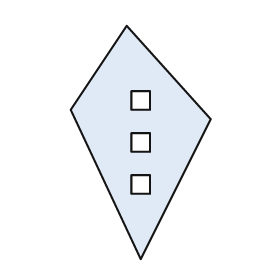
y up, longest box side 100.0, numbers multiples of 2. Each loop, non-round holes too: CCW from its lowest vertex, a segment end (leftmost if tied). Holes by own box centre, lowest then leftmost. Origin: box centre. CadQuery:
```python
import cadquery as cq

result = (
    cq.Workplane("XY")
    .moveTo(0.0, -50.0)
    .lineTo(30.0, 10.0)
    .lineTo(-6.0, 50.0)
    .lineTo(-30.0, 14.0)
    .close()
    .moveTo(-4.0, -22.0)
    .lineTo(4.0, -22.0)
    .lineTo(4.0, -14.0)
    .lineTo(-4.0, -14.0)
    .close()
    .moveTo(-4.0, -4.0)
    .lineTo(4.0, -4.0)
    .lineTo(4.0, 4.0)
    .lineTo(-4.0, 4.0)
    .close()
    .moveTo(-4.0, 14.0)
    .lineTo(4.0, 14.0)
    .lineTo(4.0, 22.0)
    .lineTo(-4.0, 22.0)
    .close()
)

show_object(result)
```